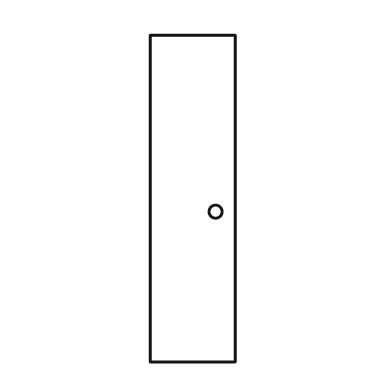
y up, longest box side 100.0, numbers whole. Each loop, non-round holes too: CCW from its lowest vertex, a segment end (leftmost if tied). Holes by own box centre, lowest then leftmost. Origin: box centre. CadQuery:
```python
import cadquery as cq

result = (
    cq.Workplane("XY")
    .moveTo(-13.0, -50.0)
    .lineTo(13.0, -50.0)
    .lineTo(13.0, 50.0)
    .lineTo(-13.0, 50.0)
    .close()
    .moveTo(7.0, -4.0)
    .circle(2.0)
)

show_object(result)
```